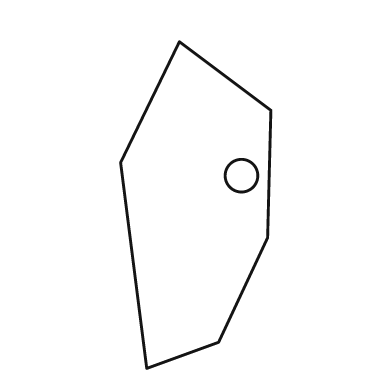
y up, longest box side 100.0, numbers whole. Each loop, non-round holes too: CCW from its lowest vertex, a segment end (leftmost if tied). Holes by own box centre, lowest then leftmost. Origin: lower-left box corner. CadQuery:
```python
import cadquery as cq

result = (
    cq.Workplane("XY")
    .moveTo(8.0, 0.0)
    .lineTo(30.0, 8.0)
    .lineTo(45.0, 40.0)
    .lineTo(46.0, 79.0)
    .lineTo(18.0, 100.0)
    .lineTo(0.0, 63.0)
    .close()
    .moveTo(37.0, 59.0)
    .circle(5.0)
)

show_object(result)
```